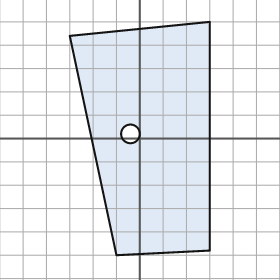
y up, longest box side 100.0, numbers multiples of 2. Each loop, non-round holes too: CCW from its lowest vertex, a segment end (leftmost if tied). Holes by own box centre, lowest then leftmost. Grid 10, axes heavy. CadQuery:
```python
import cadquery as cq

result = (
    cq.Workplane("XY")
    .moveTo(-10.0, -50.0)
    .lineTo(30.0, -48.0)
    .lineTo(30.0, 50.0)
    .lineTo(-30.0, 44.0)
    .close()
    .moveTo(-4.0, 2.0)
    .circle(4.0)
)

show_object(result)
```